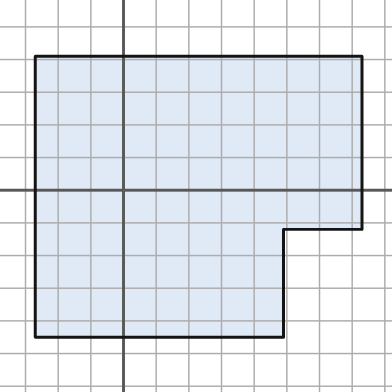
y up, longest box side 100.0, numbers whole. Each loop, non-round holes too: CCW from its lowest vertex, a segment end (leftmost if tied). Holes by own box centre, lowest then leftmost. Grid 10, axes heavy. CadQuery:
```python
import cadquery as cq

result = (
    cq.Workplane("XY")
    .moveTo(-27.0, -45.0)
    .lineTo(49.0, -45.0)
    .lineTo(49.0, -12.0)
    .lineTo(73.0, -12.0)
    .lineTo(73.0, 41.0)
    .lineTo(-27.0, 41.0)
    .close()
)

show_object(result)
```